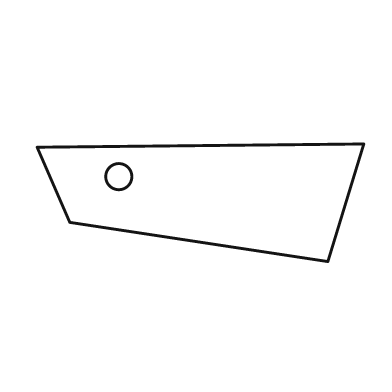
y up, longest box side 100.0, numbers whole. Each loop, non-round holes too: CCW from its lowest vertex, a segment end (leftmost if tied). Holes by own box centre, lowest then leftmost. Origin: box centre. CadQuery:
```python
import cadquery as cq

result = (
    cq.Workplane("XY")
    .moveTo(39.0, -18.0)
    .lineTo(50.0, 18.0)
    .lineTo(-50.0, 17.0)
    .lineTo(-40.0, -6.0)
    .close()
    .moveTo(-25.0, 8.0)
    .circle(4.0)
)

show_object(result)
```